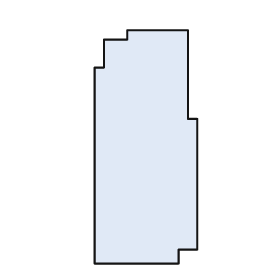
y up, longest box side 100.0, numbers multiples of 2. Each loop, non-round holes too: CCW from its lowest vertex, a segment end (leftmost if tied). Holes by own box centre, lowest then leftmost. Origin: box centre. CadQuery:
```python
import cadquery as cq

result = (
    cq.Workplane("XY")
    .moveTo(-22.0, -50.0)
    .lineTo(14.0, -50.0)
    .lineTo(14.0, -44.0)
    .lineTo(22.0, -44.0)
    .lineTo(22.0, 12.0)
    .lineTo(18.0, 12.0)
    .lineTo(18.0, 50.0)
    .lineTo(-8.0, 50.0)
    .lineTo(-8.0, 46.0)
    .lineTo(-18.0, 46.0)
    .lineTo(-18.0, 34.0)
    .lineTo(-22.0, 34.0)
    .close()
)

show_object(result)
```